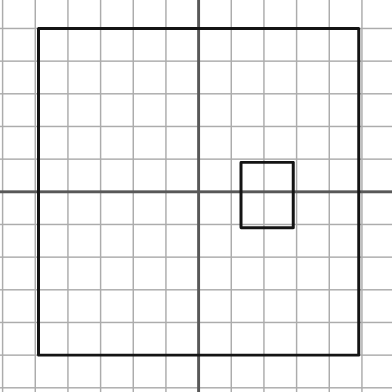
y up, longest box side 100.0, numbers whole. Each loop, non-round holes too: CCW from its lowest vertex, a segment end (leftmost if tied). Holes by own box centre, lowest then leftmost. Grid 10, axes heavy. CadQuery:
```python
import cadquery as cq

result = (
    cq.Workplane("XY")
    .moveTo(-49.0, -50.0)
    .lineTo(49.0, -50.0)
    .lineTo(49.0, 50.0)
    .lineTo(-49.0, 50.0)
    .close()
    .moveTo(13.0, -11.0)
    .lineTo(29.0, -11.0)
    .lineTo(29.0, 9.0)
    .lineTo(13.0, 9.0)
    .close()
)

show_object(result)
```